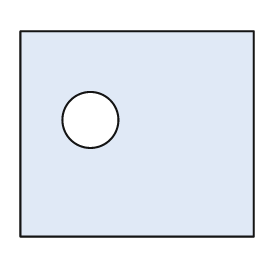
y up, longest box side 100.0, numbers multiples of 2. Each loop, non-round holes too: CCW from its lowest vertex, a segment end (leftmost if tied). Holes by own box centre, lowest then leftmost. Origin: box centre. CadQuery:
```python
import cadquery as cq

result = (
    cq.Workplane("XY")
    .moveTo(-50.0, -44.0)
    .lineTo(50.0, -44.0)
    .lineTo(50.0, 44.0)
    .lineTo(-50.0, 44.0)
    .close()
    .moveTo(-20.0, 6.0)
    .circle(12.0)
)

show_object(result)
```